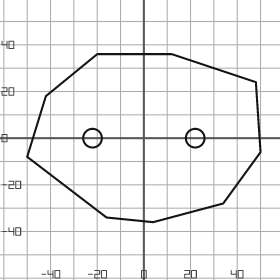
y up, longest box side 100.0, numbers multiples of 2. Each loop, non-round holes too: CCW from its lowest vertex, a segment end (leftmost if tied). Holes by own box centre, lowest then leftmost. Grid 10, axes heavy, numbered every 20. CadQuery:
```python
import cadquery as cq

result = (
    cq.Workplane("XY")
    .moveTo(4.0, -36.0)
    .lineTo(34.0, -28.0)
    .lineTo(50.0, -6.0)
    .lineTo(48.0, 24.0)
    .lineTo(12.0, 36.0)
    .lineTo(-20.0, 36.0)
    .lineTo(-42.0, 18.0)
    .lineTo(-50.0, -8.0)
    .lineTo(-16.0, -34.0)
    .close()
    .moveTo(-22.0, 0.0)
    .circle(4.0)
    .moveTo(22.0, 0.0)
    .circle(4.0)
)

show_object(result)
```